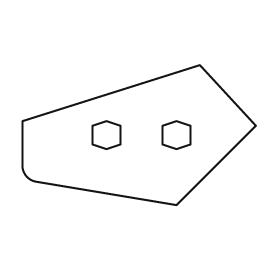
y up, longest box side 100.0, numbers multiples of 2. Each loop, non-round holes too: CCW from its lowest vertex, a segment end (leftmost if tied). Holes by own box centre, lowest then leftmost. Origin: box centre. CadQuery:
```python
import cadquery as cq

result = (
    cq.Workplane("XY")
    .moveTo(16.0, -30.0)
    .lineTo(50.0, 4.0)
    .lineTo(26.0, 30.0)
    .lineTo(-50.0, 6.0)
    .lineTo(-50.0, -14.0)
    .threePointArc((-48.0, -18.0), (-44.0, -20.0))
    .close()
    .moveTo(-14.0, -6.0)
    .lineTo(-8.0, -4.0)
    .lineTo(-8.0, 4.0)
    .lineTo(-14.0, 6.0)
    .lineTo(-20.0, 4.0)
    .lineTo(-20.0, -4.0)
    .close()
    .moveTo(16.0, -6.0)
    .lineTo(22.0, -4.0)
    .lineTo(22.0, 4.0)
    .lineTo(16.0, 6.0)
    .lineTo(10.0, 4.0)
    .lineTo(10.0, -4.0)
    .close()
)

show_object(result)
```